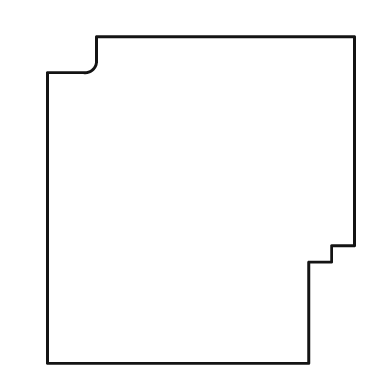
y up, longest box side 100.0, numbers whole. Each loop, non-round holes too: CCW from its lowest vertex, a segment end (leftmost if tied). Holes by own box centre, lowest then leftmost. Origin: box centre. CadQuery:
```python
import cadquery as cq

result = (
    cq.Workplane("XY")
    .moveTo(-47.0, -50.0)
    .lineTo(33.0, -50.0)
    .lineTo(33.0, -19.0)
    .lineTo(40.0, -19.0)
    .lineTo(40.0, -14.0)
    .lineTo(47.0, -14.0)
    .lineTo(47.0, 50.0)
    .lineTo(-32.0, 50.0)
    .lineTo(-32.0, 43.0)
    .threePointArc((-33.0, 40.0), (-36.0, 39.0))
    .lineTo(-47.0, 39.0)
    .close()
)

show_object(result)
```